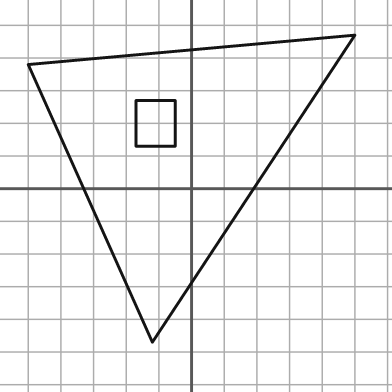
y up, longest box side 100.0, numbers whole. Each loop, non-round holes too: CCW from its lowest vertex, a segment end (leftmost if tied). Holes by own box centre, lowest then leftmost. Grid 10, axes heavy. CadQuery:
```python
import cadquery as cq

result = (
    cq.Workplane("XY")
    .moveTo(-12.0, -47.0)
    .lineTo(50.0, 47.0)
    .lineTo(-50.0, 38.0)
    .close()
    .moveTo(-17.0, 13.0)
    .lineTo(-5.0, 13.0)
    .lineTo(-5.0, 27.0)
    .lineTo(-17.0, 27.0)
    .close()
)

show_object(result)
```